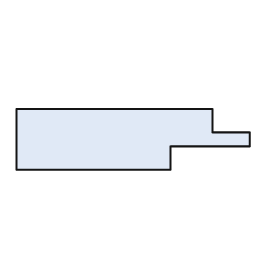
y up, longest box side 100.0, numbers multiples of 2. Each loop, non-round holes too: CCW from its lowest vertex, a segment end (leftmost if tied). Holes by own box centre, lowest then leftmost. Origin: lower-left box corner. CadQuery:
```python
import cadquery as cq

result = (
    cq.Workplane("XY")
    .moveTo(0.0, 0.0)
    .lineTo(66.0, 0.0)
    .lineTo(66.0, 10.0)
    .lineTo(100.0, 10.0)
    .lineTo(100.0, 16.0)
    .lineTo(84.0, 16.0)
    .lineTo(84.0, 26.0)
    .lineTo(0.0, 26.0)
    .close()
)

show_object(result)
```